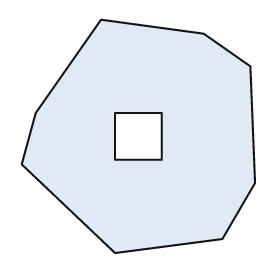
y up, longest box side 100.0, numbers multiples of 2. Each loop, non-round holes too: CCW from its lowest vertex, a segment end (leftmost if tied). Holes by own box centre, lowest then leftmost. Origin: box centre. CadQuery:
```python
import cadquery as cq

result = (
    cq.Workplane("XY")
    .moveTo(-10.0, -50.0)
    .lineTo(36.0, -44.0)
    .lineTo(50.0, -20.0)
    .lineTo(48.0, 30.0)
    .lineTo(28.0, 44.0)
    .lineTo(-16.0, 50.0)
    .lineTo(-44.0, 10.0)
    .lineTo(-50.0, -12.0)
    .close()
    .moveTo(-10.0, -10.0)
    .lineTo(10.0, -10.0)
    .lineTo(10.0, 10.0)
    .lineTo(-10.0, 10.0)
    .close()
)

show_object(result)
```